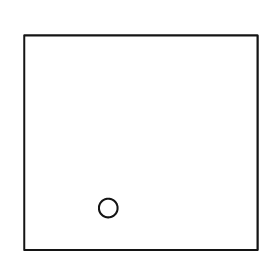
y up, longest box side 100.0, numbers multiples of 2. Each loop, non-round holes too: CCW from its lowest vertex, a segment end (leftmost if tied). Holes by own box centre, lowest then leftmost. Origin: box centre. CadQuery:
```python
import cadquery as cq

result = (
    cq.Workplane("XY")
    .moveTo(-50.0, -46.0)
    .lineTo(50.0, -46.0)
    .lineTo(50.0, 46.0)
    .lineTo(-50.0, 46.0)
    .close()
    .moveTo(-14.0, -28.0)
    .circle(4.0)
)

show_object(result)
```